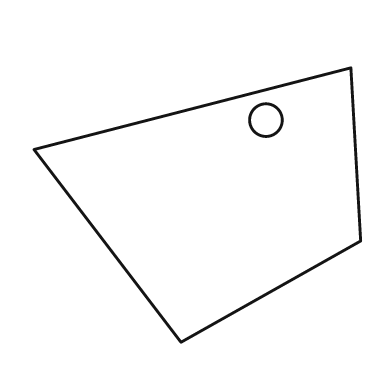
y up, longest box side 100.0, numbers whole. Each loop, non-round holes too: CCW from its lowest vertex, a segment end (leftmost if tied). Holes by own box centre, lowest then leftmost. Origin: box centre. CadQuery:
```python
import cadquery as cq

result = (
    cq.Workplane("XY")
    .moveTo(-5.0, -42.0)
    .lineTo(50.0, -11.0)
    .lineTo(47.0, 42.0)
    .lineTo(-50.0, 17.0)
    .close()
    .moveTo(21.0, 26.0)
    .circle(5.0)
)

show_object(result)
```